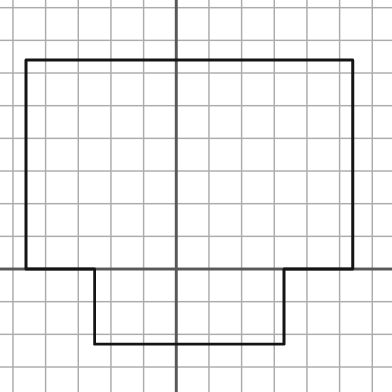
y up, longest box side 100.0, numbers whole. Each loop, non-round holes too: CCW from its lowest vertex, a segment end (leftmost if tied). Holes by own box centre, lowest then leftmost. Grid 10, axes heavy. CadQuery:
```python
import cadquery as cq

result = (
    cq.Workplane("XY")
    .moveTo(-25.0, -23.0)
    .lineTo(33.0, -23.0)
    .lineTo(33.0, 0.0)
    .lineTo(54.0, 0.0)
    .lineTo(54.0, 64.0)
    .lineTo(-46.0, 64.0)
    .lineTo(-46.0, 0.0)
    .lineTo(-25.0, 0.0)
    .close()
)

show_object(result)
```